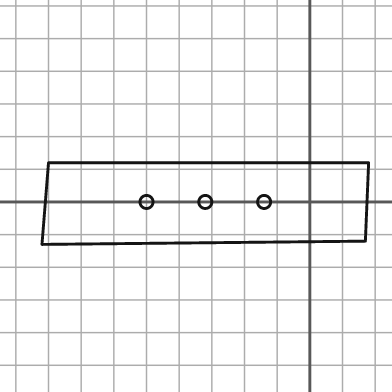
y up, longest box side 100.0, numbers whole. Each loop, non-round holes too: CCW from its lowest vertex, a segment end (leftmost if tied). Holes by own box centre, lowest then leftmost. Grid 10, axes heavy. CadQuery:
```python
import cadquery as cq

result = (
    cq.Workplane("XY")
    .moveTo(-82.0, -13.0)
    .lineTo(17.0, -12.0)
    .lineTo(18.0, 12.0)
    .lineTo(-80.0, 12.0)
    .close()
    .moveTo(-50.0, 0.0)
    .circle(2.0)
    .moveTo(-32.0, 0.0)
    .circle(2.0)
    .moveTo(-14.0, 0.0)
    .circle(2.0)
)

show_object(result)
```